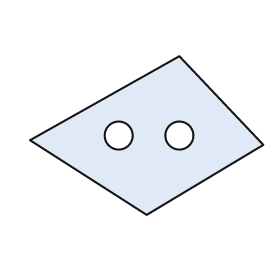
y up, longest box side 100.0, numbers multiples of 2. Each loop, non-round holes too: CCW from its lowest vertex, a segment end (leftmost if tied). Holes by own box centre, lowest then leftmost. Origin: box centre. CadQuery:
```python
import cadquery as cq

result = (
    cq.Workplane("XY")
    .moveTo(0.0, -34.0)
    .lineTo(50.0, -4.0)
    .lineTo(14.0, 34.0)
    .lineTo(-50.0, -2.0)
    .close()
    .moveTo(-12.0, 0.0)
    .circle(6.0)
    .moveTo(14.0, 0.0)
    .circle(6.0)
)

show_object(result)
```